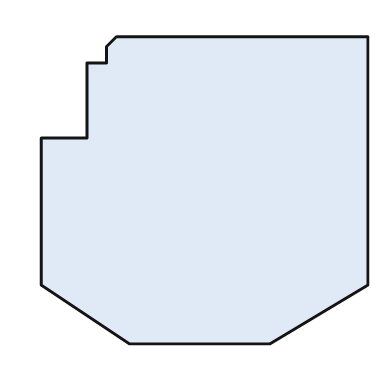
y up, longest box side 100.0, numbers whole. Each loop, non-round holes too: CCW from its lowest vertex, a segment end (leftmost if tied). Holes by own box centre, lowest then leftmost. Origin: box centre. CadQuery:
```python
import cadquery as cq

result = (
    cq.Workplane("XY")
    .moveTo(-23.0, -47.0)
    .lineTo(20.0, -47.0)
    .lineTo(50.0, -29.0)
    .lineTo(50.0, 47.0)
    .lineTo(-27.0, 47.0)
    .lineTo(-30.0, 44.0)
    .lineTo(-30.0, 39.0)
    .lineTo(-36.0, 39.0)
    .lineTo(-36.0, 16.0)
    .lineTo(-50.0, 16.0)
    .lineTo(-50.0, -29.0)
    .close()
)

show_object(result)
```